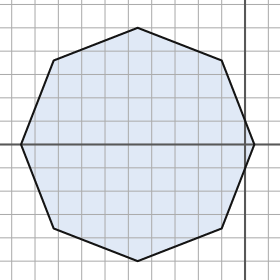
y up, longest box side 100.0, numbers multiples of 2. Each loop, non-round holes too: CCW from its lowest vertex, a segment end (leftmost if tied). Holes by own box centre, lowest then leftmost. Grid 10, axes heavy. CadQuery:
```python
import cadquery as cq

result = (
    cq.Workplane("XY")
    .moveTo(-46.0, -50.0)
    .lineTo(-10.0, -36.0)
    .lineTo(4.0, 0.0)
    .lineTo(-10.0, 36.0)
    .lineTo(-46.0, 50.0)
    .lineTo(-82.0, 36.0)
    .lineTo(-96.0, 0.0)
    .lineTo(-82.0, -36.0)
    .close()
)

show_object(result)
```